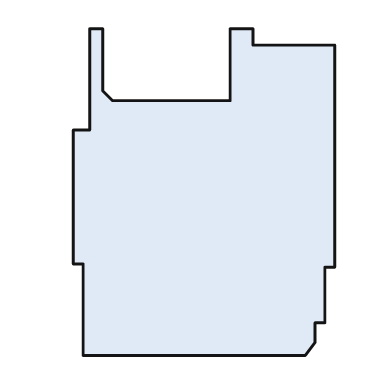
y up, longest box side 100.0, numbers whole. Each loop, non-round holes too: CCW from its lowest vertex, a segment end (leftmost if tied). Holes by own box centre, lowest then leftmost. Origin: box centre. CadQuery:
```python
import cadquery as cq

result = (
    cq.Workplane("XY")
    .moveTo(-37.0, -50.0)
    .lineTo(31.0, -50.0)
    .lineTo(34.0, -46.0)
    .lineTo(34.0, -40.0)
    .lineTo(37.0, -40.0)
    .lineTo(37.0, -23.0)
    .lineTo(40.0, -23.0)
    .lineTo(40.0, 45.0)
    .lineTo(15.0, 45.0)
    .lineTo(15.0, 50.0)
    .lineTo(8.0, 50.0)
    .lineTo(8.0, 28.0)
    .lineTo(-28.0, 28.0)
    .lineTo(-31.0, 31.0)
    .lineTo(-31.0, 50.0)
    .lineTo(-35.0, 50.0)
    .lineTo(-35.0, 19.0)
    .lineTo(-40.0, 19.0)
    .lineTo(-40.0, -22.0)
    .lineTo(-37.0, -22.0)
    .close()
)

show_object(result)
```